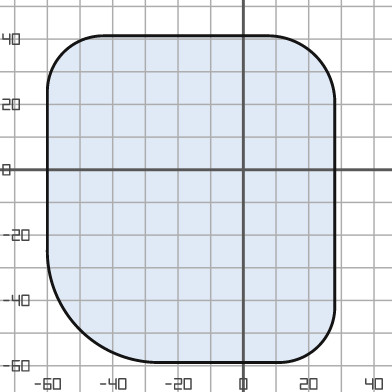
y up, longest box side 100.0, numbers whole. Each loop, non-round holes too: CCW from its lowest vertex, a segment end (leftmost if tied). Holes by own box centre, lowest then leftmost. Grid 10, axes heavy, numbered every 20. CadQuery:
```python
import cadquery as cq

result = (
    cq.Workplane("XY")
    .moveTo(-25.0, -59.0)
    .lineTo(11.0, -59.0)
    .threePointArc((23.0, -54.0), (28.0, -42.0))
    .lineTo(28.0, 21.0)
    .threePointArc((22.0, 35.0), (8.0, 41.0))
    .lineTo(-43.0, 41.0)
    .threePointArc((-55.0, 36.0), (-60.0, 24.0))
    .lineTo(-60.0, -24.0)
    .threePointArc((-50.0, -49.0), (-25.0, -59.0))
    .close()
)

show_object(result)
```